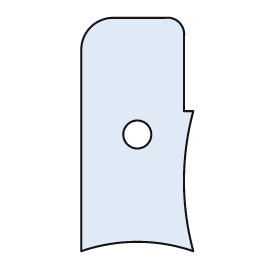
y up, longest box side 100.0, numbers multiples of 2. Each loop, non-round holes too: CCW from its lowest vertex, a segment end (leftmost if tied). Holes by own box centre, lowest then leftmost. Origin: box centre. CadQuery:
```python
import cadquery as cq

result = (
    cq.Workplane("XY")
    .moveTo(-24.0, -50.0)
    .threePointArc((0.0, -46.0), (24.0, -50.0))
    .threePointArc((20.0, -20.0), (24.0, 10.0))
    .lineTo(20.0, 10.0)
    .lineTo(20.0, 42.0)
    .threePointArc((18.0, 48.0), (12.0, 50.0))
    .lineTo(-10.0, 50.0)
    .threePointArc((-20.0, 46.0), (-24.0, 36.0))
    .close()
    .moveTo(0.0, 0.0)
    .circle(6.0)
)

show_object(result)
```